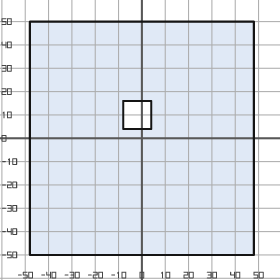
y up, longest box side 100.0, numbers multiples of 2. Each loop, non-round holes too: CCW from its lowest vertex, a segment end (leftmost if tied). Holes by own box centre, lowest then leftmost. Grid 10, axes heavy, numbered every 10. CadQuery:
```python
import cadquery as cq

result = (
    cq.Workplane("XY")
    .moveTo(-48.0, -50.0)
    .lineTo(48.0, -50.0)
    .lineTo(48.0, 50.0)
    .lineTo(-48.0, 50.0)
    .close()
    .moveTo(-8.0, 4.0)
    .lineTo(4.0, 4.0)
    .lineTo(4.0, 16.0)
    .lineTo(-8.0, 16.0)
    .close()
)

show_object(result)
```